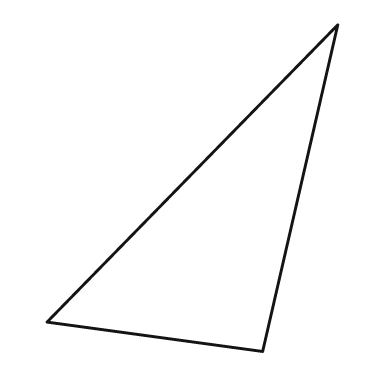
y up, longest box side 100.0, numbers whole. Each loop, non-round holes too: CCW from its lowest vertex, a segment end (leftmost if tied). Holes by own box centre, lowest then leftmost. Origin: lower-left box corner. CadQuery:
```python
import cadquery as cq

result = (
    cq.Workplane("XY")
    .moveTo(66.0, 0.0)
    .lineTo(89.0, 100.0)
    .lineTo(0.0, 9.0)
    .close()
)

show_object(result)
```